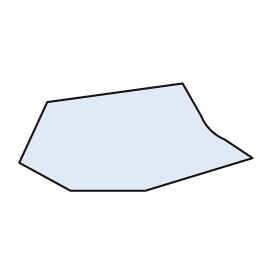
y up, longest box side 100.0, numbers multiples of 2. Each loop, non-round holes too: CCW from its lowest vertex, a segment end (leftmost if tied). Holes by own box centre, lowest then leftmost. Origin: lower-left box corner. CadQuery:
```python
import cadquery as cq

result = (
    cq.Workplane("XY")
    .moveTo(22.0, 0.0)
    .lineTo(54.0, 0.0)
    .lineTo(100.0, 14.0)
    .lineTo(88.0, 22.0)
    .threePointArc((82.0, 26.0), (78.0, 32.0))
    .lineTo(70.0, 46.0)
    .lineTo(12.0, 38.0)
    .lineTo(0.0, 12.0)
    .close()
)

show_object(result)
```